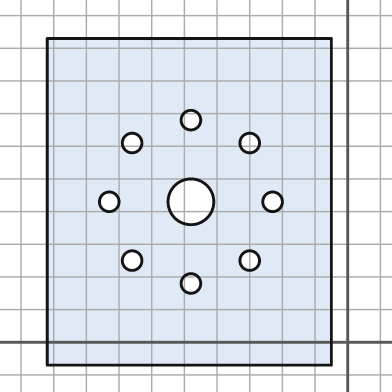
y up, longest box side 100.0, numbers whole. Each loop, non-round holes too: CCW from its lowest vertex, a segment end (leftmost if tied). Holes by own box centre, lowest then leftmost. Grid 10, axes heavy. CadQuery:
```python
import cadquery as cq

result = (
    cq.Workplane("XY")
    .moveTo(-92.0, -7.0)
    .lineTo(-5.0, -7.0)
    .lineTo(-5.0, 93.0)
    .lineTo(-92.0, 93.0)
    .close()
    .moveTo(-48.0, 18.0)
    .circle(3.0)
    .moveTo(-66.0, 25.0)
    .circle(3.0)
    .moveTo(-30.0, 25.0)
    .circle(3.0)
    .moveTo(-73.0, 43.0)
    .circle(3.0)
    .moveTo(-48.0, 43.0)
    .circle(7.0)
    .moveTo(-23.0, 43.0)
    .circle(3.0)
    .moveTo(-66.0, 61.0)
    .circle(3.0)
    .moveTo(-30.0, 61.0)
    .circle(3.0)
    .moveTo(-48.0, 68.0)
    .circle(3.0)
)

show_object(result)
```